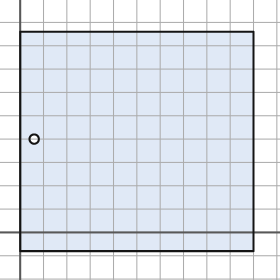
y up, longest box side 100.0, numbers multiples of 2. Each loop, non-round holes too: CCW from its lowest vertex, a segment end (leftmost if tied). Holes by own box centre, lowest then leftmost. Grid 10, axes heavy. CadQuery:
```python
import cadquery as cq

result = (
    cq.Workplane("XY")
    .moveTo(0.0, -8.0)
    .lineTo(100.0, -8.0)
    .lineTo(100.0, 86.0)
    .lineTo(0.0, 86.0)
    .close()
    .moveTo(6.0, 40.0)
    .circle(2.0)
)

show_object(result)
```